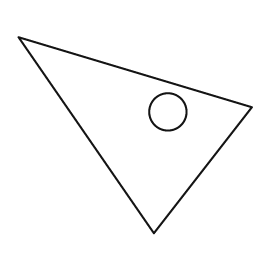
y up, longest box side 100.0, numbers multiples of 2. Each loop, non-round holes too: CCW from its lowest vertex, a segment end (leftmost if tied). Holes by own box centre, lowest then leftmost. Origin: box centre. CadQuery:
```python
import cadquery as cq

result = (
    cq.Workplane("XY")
    .moveTo(8.0, -42.0)
    .lineTo(50.0, 12.0)
    .lineTo(-50.0, 42.0)
    .close()
    .moveTo(14.0, 10.0)
    .circle(8.0)
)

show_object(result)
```